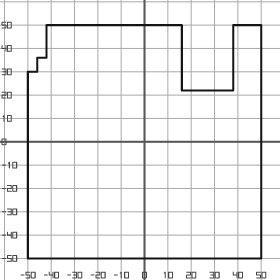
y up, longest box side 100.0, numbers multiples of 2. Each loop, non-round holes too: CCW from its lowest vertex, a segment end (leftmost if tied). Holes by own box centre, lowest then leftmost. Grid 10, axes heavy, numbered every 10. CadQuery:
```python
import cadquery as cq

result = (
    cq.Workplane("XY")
    .moveTo(-50.0, -50.0)
    .lineTo(50.0, -50.0)
    .lineTo(50.0, 50.0)
    .lineTo(38.0, 50.0)
    .lineTo(38.0, 22.0)
    .lineTo(16.0, 22.0)
    .lineTo(16.0, 50.0)
    .lineTo(-42.0, 50.0)
    .lineTo(-42.0, 36.0)
    .lineTo(-46.0, 36.0)
    .lineTo(-46.0, 30.0)
    .lineTo(-50.0, 30.0)
    .close()
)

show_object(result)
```